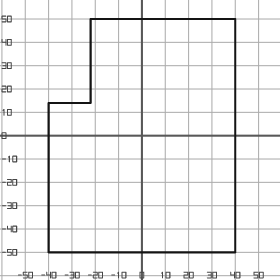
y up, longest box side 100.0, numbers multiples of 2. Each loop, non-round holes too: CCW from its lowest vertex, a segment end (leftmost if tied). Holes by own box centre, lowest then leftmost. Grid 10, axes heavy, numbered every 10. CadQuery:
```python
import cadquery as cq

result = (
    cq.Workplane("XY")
    .moveTo(-40.0, -50.0)
    .lineTo(40.0, -50.0)
    .lineTo(40.0, 50.0)
    .lineTo(-22.0, 50.0)
    .lineTo(-22.0, 14.0)
    .lineTo(-40.0, 14.0)
    .close()
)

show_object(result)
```